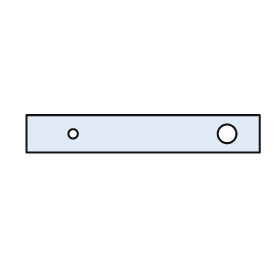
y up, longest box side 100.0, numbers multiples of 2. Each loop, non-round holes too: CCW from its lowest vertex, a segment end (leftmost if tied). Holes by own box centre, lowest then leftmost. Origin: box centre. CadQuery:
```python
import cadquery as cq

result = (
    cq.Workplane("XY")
    .moveTo(-50.0, -8.0)
    .lineTo(50.0, -8.0)
    .lineTo(50.0, 8.0)
    .lineTo(-50.0, 8.0)
    .close()
    .moveTo(-30.0, 0.0)
    .circle(2.0)
    .moveTo(36.0, 0.0)
    .circle(4.0)
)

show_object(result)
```